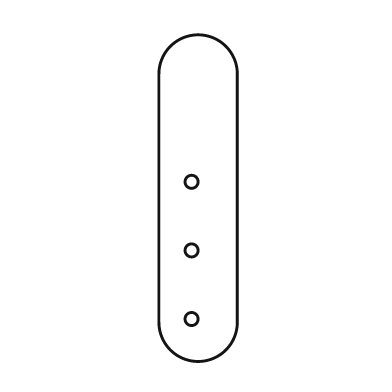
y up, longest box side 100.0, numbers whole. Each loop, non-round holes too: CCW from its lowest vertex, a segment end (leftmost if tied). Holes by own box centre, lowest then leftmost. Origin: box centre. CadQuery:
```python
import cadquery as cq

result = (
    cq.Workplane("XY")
    .moveTo(-12.0, -38.0)
    .threePointArc((0.0, -50.0), (12.0, -38.0))
    .lineTo(12.0, 38.0)
    .threePointArc((0.0, 50.0), (-12.0, 38.0))
    .close()
    .moveTo(-2.0, -37.0)
    .circle(2.0)
    .moveTo(-2.0, -16.0)
    .circle(2.0)
    .moveTo(-2.0, 5.0)
    .circle(2.0)
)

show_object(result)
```